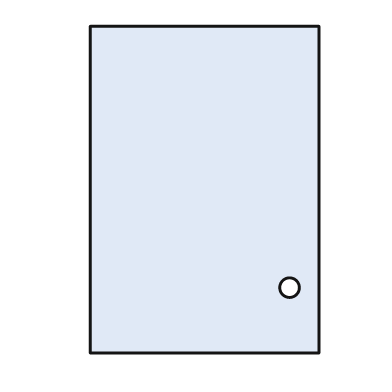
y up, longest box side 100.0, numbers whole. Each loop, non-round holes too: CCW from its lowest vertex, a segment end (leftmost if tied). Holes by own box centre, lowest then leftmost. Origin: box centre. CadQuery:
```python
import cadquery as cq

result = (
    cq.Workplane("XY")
    .moveTo(-35.0, -50.0)
    .lineTo(35.0, -50.0)
    .lineTo(35.0, 50.0)
    .lineTo(-35.0, 50.0)
    .close()
    .moveTo(26.0, -30.0)
    .circle(3.0)
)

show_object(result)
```